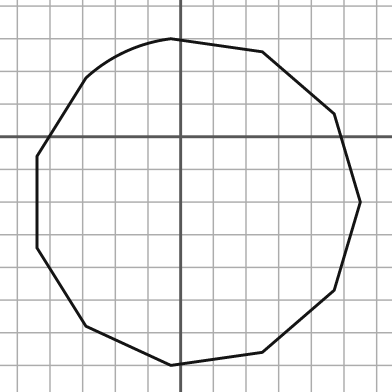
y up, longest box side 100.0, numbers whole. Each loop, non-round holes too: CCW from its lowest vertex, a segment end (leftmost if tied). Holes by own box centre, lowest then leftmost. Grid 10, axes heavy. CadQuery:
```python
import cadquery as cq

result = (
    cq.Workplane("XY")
    .moveTo(-3.0, -70.0)
    .lineTo(25.0, -66.0)
    .lineTo(47.0, -47.0)
    .lineTo(55.0, -20.0)
    .lineTo(47.0, 7.0)
    .lineTo(25.0, 26.0)
    .lineTo(-3.0, 30.0)
    .threePointArc((-17.0, 26.0), (-29.0, 18.0))
    .lineTo(-44.0, -6.0)
    .lineTo(-44.0, -34.0)
    .lineTo(-29.0, -58.0)
    .close()
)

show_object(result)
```